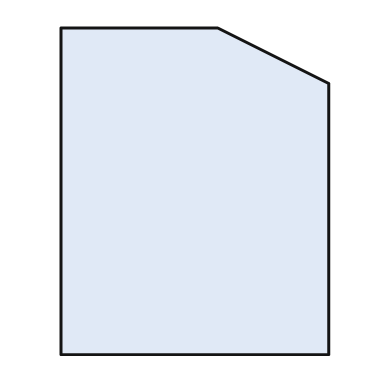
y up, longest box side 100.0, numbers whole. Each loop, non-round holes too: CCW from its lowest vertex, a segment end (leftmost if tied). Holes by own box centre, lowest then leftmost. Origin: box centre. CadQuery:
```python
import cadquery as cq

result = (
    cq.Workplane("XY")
    .moveTo(-41.0, -50.0)
    .lineTo(41.0, -50.0)
    .lineTo(41.0, 33.0)
    .lineTo(7.0, 50.0)
    .lineTo(-41.0, 50.0)
    .close()
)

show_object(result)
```